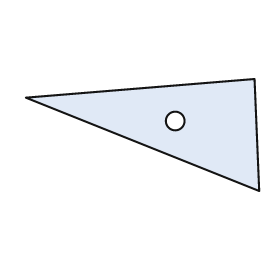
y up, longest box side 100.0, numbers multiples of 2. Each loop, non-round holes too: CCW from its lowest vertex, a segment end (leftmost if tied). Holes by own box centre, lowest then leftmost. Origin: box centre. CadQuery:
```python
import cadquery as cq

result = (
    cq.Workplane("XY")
    .moveTo(50.0, -24.0)
    .lineTo(48.0, 24.0)
    .lineTo(-50.0, 16.0)
    .close()
    .moveTo(14.0, 6.0)
    .circle(4.0)
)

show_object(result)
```